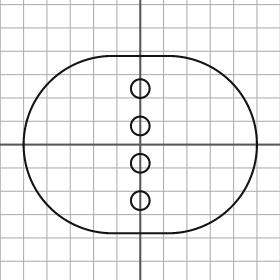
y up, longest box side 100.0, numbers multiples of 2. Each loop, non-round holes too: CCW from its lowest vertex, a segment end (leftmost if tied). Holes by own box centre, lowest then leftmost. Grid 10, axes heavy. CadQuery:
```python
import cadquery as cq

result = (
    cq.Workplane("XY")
    .moveTo(-12.0, -38.0)
    .lineTo(12.0, -38.0)
    .threePointArc((50.0, 0.0), (12.0, 38.0))
    .lineTo(-12.0, 38.0)
    .threePointArc((-50.0, 0.0), (-12.0, -38.0))
    .close()
    .moveTo(0.0, -24.0)
    .circle(4.0)
    .moveTo(0.0, -8.0)
    .circle(4.0)
    .moveTo(0.0, 8.0)
    .circle(4.0)
    .moveTo(0.0, 24.0)
    .circle(4.0)
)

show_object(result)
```